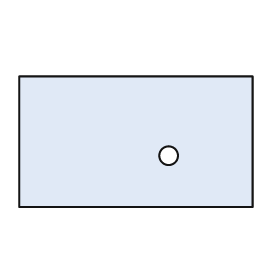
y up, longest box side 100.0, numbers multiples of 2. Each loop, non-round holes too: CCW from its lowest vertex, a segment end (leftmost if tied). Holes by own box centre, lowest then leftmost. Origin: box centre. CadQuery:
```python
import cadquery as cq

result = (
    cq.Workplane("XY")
    .moveTo(-50.0, -28.0)
    .lineTo(50.0, -28.0)
    .lineTo(50.0, 28.0)
    .lineTo(-50.0, 28.0)
    .close()
    .moveTo(14.0, -6.0)
    .circle(4.0)
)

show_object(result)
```